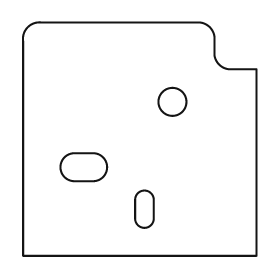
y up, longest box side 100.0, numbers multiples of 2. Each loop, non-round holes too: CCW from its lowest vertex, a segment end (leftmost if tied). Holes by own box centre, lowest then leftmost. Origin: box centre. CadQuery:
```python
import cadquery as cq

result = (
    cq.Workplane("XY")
    .moveTo(-50.0, -50.0)
    .lineTo(50.0, -50.0)
    .lineTo(50.0, 30.0)
    .lineTo(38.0, 30.0)
    .threePointArc((34.0, 32.0), (32.0, 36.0))
    .lineTo(32.0, 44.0)
    .threePointArc((30.0, 48.0), (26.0, 50.0))
    .lineTo(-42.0, 50.0)
    .threePointArc((-48.0, 48.0), (-50.0, 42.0))
    .close()
    .moveTo(-2.0, -34.0)
    .threePointArc((2.0, -38.0), (6.0, -34.0))
    .lineTo(6.0, -26.0)
    .threePointArc((2.0, -22.0), (-2.0, -26.0))
    .close()
    .moveTo(-28.0, -18.0)
    .lineTo(-20.0, -18.0)
    .threePointArc((-14.0, -12.0), (-20.0, -6.0))
    .lineTo(-28.0, -6.0)
    .threePointArc((-34.0, -12.0), (-28.0, -18.0))
    .close()
    .moveTo(14.0, 16.0)
    .circle(6.0)
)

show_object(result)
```